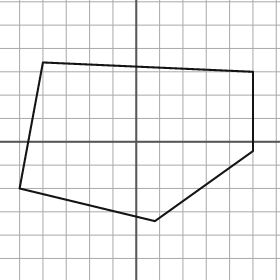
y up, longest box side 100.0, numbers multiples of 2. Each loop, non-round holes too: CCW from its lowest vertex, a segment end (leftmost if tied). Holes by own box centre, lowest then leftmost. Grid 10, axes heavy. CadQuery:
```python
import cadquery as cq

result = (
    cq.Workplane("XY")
    .moveTo(8.0, -34.0)
    .lineTo(50.0, -4.0)
    .lineTo(50.0, 30.0)
    .lineTo(-40.0, 34.0)
    .lineTo(-50.0, -20.0)
    .close()
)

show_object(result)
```